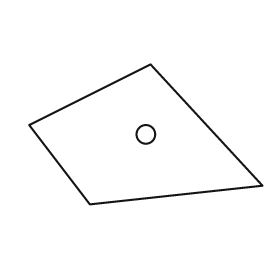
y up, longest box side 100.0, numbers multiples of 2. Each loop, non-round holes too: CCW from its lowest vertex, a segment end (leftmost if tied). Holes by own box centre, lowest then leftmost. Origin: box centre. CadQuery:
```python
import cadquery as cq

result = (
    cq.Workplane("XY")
    .moveTo(-24.0, -30.0)
    .lineTo(50.0, -22.0)
    .lineTo(2.0, 30.0)
    .lineTo(-50.0, 4.0)
    .close()
    .moveTo(0.0, 0.0)
    .circle(4.0)
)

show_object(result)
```